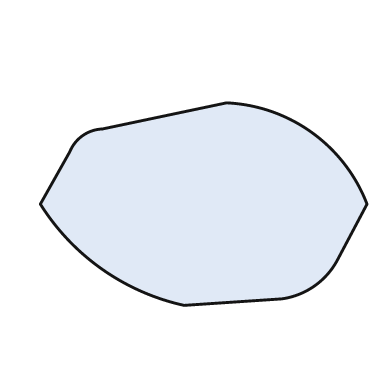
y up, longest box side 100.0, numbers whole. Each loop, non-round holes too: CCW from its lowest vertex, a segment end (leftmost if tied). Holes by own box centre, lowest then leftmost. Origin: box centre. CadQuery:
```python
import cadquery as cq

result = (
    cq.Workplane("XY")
    .moveTo(-6.0, -31.0)
    .lineTo(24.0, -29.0)
    .threePointArc((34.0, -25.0), (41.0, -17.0))
    .lineTo(50.0, 0.0)
    .threePointArc((33.0, 22.0), (7.0, 31.0))
    .lineTo(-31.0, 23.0)
    .threePointArc((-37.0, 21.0), (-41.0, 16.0))
    .lineTo(-50.0, 0.0)
    .threePointArc((-31.0, -20.0), (-6.0, -31.0))
    .close()
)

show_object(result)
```